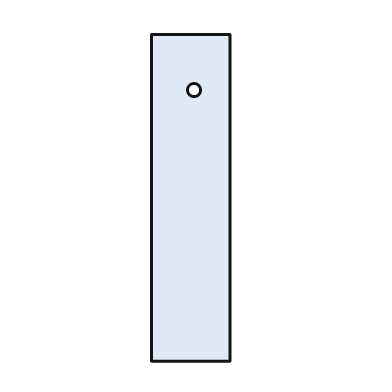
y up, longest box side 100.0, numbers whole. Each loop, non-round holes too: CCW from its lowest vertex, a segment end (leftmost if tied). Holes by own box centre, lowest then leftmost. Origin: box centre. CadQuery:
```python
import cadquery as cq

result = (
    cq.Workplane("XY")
    .moveTo(-12.0, -50.0)
    .lineTo(12.0, -50.0)
    .lineTo(12.0, 50.0)
    .lineTo(-12.0, 50.0)
    .close()
    .moveTo(1.0, 33.0)
    .circle(2.0)
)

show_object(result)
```